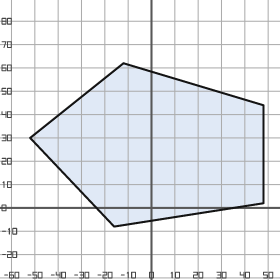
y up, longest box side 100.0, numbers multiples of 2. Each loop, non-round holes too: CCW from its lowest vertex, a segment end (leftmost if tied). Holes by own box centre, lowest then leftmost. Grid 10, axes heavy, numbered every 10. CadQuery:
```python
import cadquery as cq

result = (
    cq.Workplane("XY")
    .moveTo(-16.0, -8.0)
    .lineTo(48.0, 2.0)
    .lineTo(48.0, 44.0)
    .lineTo(-12.0, 62.0)
    .lineTo(-52.0, 30.0)
    .close()
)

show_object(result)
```